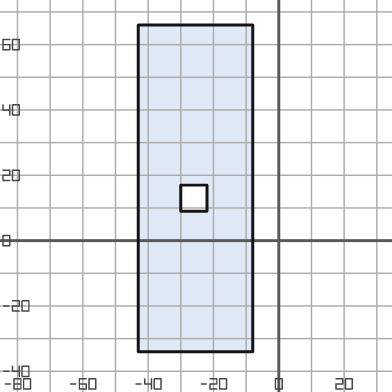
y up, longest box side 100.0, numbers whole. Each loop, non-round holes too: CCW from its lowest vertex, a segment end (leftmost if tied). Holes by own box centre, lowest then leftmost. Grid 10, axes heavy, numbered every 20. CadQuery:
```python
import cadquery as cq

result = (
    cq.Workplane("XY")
    .moveTo(-43.0, -34.0)
    .lineTo(-8.0, -34.0)
    .lineTo(-8.0, 66.0)
    .lineTo(-43.0, 66.0)
    .close()
    .moveTo(-30.0, 9.0)
    .lineTo(-22.0, 9.0)
    .lineTo(-22.0, 17.0)
    .lineTo(-30.0, 17.0)
    .close()
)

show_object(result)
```